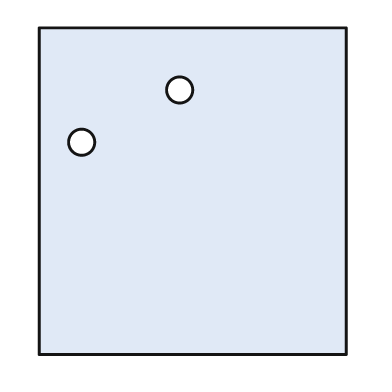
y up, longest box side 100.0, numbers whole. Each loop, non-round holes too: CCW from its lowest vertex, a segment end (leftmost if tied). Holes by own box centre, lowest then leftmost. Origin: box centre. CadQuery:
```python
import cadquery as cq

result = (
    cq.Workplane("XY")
    .moveTo(-47.0, -50.0)
    .lineTo(47.0, -50.0)
    .lineTo(47.0, 50.0)
    .lineTo(-47.0, 50.0)
    .close()
    .moveTo(-34.0, 15.0)
    .circle(4.0)
    .moveTo(-4.0, 31.0)
    .circle(4.0)
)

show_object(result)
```